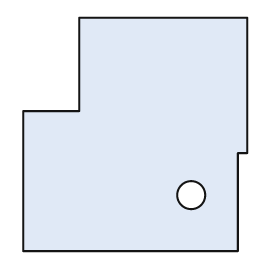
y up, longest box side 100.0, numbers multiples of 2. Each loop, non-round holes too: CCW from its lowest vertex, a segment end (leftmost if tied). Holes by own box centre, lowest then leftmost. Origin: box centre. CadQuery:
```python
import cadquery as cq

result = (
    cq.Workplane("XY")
    .moveTo(-48.0, -50.0)
    .lineTo(44.0, -50.0)
    .lineTo(44.0, -8.0)
    .lineTo(48.0, -8.0)
    .lineTo(48.0, 50.0)
    .lineTo(-24.0, 50.0)
    .lineTo(-24.0, 10.0)
    .lineTo(-48.0, 10.0)
    .close()
    .moveTo(24.0, -26.0)
    .circle(6.0)
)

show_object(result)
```